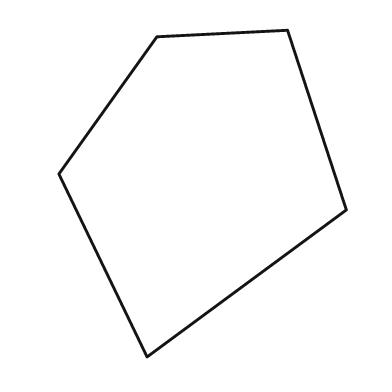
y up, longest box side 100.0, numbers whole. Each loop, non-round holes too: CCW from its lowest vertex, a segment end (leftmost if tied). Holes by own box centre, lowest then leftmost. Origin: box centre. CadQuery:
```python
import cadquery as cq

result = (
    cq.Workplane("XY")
    .moveTo(-17.0, -50.0)
    .lineTo(44.0, -5.0)
    .lineTo(26.0, 50.0)
    .lineTo(-14.0, 48.0)
    .lineTo(-44.0, 6.0)
    .close()
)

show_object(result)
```